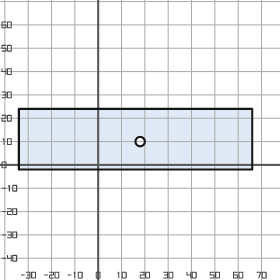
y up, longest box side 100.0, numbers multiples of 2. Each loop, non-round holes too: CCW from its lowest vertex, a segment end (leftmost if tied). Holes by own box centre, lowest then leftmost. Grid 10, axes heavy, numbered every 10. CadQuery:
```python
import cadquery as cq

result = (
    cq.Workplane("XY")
    .moveTo(-34.0, -2.0)
    .lineTo(66.0, -2.0)
    .lineTo(66.0, 24.0)
    .lineTo(-34.0, 24.0)
    .close()
    .moveTo(18.0, 10.0)
    .circle(2.0)
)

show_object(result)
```